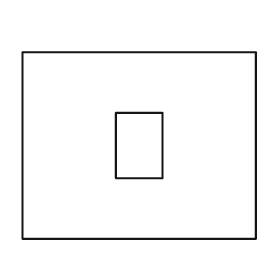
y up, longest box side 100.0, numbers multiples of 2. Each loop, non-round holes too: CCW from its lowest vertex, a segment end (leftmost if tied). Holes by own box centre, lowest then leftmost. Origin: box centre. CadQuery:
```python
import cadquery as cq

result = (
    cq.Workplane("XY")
    .moveTo(-50.0, -40.0)
    .lineTo(50.0, -40.0)
    .lineTo(50.0, 40.0)
    .lineTo(-50.0, 40.0)
    .close()
    .moveTo(-10.0, -14.0)
    .lineTo(10.0, -14.0)
    .lineTo(10.0, 14.0)
    .lineTo(-10.0, 14.0)
    .close()
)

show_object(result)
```